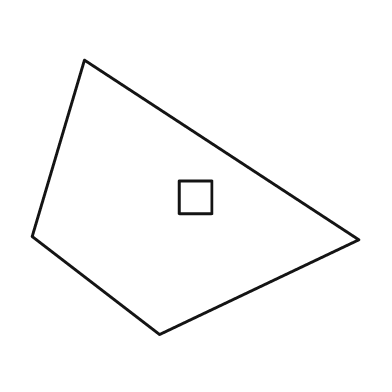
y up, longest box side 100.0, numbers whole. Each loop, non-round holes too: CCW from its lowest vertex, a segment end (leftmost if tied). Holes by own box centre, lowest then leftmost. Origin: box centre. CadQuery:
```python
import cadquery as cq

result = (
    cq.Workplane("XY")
    .moveTo(-11.0, -42.0)
    .lineTo(50.0, -13.0)
    .lineTo(-34.0, 42.0)
    .lineTo(-50.0, -12.0)
    .close()
    .moveTo(-5.0, -5.0)
    .lineTo(5.0, -5.0)
    .lineTo(5.0, 5.0)
    .lineTo(-5.0, 5.0)
    .close()
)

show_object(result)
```